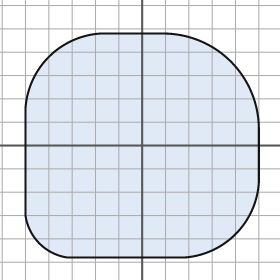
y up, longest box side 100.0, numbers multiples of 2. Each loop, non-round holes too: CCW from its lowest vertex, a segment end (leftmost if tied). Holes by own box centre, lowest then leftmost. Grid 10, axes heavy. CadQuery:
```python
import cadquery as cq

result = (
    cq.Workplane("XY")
    .moveTo(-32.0, -48.0)
    .lineTo(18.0, -48.0)
    .threePointArc((40.0, -38.0), (50.0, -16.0))
    .lineTo(50.0, 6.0)
    .threePointArc((38.0, 36.0), (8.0, 48.0))
    .lineTo(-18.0, 48.0)
    .threePointArc((-40.0, 38.0), (-50.0, 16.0))
    .lineTo(-50.0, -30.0)
    .threePointArc((-44.0, -42.0), (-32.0, -48.0))
    .close()
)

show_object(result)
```